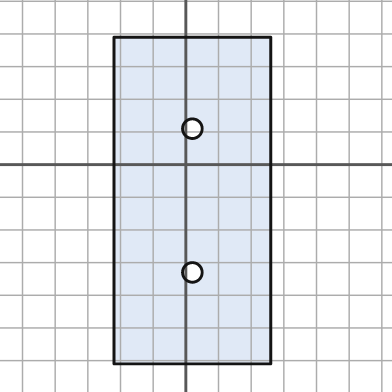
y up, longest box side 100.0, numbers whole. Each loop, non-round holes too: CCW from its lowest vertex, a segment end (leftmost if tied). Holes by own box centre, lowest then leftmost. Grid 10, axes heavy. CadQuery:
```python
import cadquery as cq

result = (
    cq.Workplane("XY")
    .moveTo(-22.0, -61.0)
    .lineTo(26.0, -61.0)
    .lineTo(26.0, 39.0)
    .lineTo(-22.0, 39.0)
    .close()
    .moveTo(2.0, -33.0)
    .circle(3.0)
    .moveTo(2.0, 11.0)
    .circle(3.0)
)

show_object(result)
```